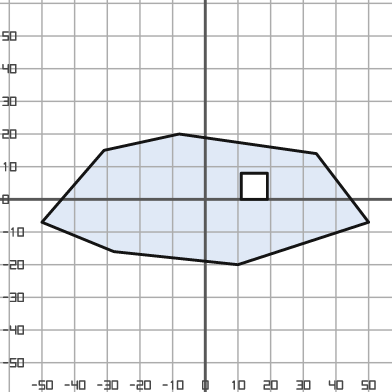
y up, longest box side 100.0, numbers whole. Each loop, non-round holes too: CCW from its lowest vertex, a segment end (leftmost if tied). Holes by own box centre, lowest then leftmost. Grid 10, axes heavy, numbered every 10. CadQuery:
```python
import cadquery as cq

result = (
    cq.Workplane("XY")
    .moveTo(10.0, -20.0)
    .lineTo(50.0, -7.0)
    .lineTo(34.0, 14.0)
    .lineTo(-8.0, 20.0)
    .lineTo(-31.0, 15.0)
    .lineTo(-50.0, -7.0)
    .lineTo(-28.0, -16.0)
    .close()
    .moveTo(11.0, 0.0)
    .lineTo(19.0, 0.0)
    .lineTo(19.0, 8.0)
    .lineTo(11.0, 8.0)
    .close()
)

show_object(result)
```